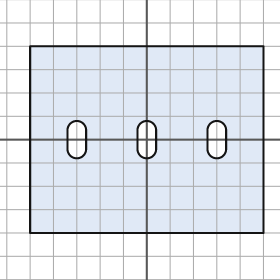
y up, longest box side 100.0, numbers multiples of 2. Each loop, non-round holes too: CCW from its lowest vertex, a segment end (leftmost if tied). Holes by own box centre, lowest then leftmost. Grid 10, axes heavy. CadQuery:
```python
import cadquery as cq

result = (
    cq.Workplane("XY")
    .moveTo(-50.0, -40.0)
    .lineTo(50.0, -40.0)
    .lineTo(50.0, 40.0)
    .lineTo(-50.0, 40.0)
    .close()
    .moveTo(-34.0, -4.0)
    .threePointArc((-30.0, -8.0), (-26.0, -4.0))
    .lineTo(-26.0, 4.0)
    .threePointArc((-30.0, 8.0), (-34.0, 4.0))
    .close()
    .moveTo(-4.0, -4.0)
    .threePointArc((0.0, -8.0), (4.0, -4.0))
    .lineTo(4.0, 4.0)
    .threePointArc((0.0, 8.0), (-4.0, 4.0))
    .close()
    .moveTo(26.0, -4.0)
    .threePointArc((30.0, -8.0), (34.0, -4.0))
    .lineTo(34.0, 4.0)
    .threePointArc((30.0, 8.0), (26.0, 4.0))
    .close()
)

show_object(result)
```